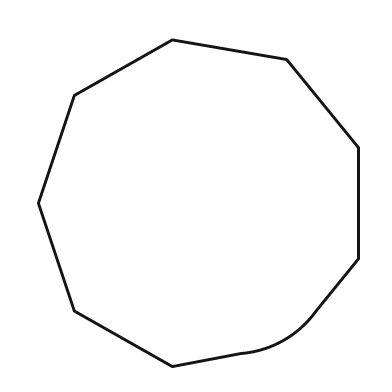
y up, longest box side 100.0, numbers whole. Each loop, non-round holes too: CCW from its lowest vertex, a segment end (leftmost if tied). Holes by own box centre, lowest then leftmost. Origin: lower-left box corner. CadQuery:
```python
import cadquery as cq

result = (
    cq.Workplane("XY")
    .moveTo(41.0, 0.0)
    .lineTo(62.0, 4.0)
    .threePointArc((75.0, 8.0), (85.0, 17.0))
    .lineTo(98.0, 33.0)
    .lineTo(98.0, 67.0)
    .lineTo(76.0, 94.0)
    .lineTo(41.0, 100.0)
    .lineTo(11.0, 83.0)
    .lineTo(0.0, 50.0)
    .lineTo(11.0, 17.0)
    .close()
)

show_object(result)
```